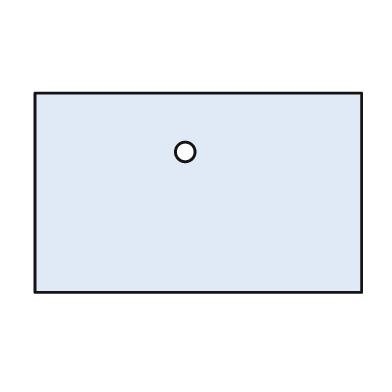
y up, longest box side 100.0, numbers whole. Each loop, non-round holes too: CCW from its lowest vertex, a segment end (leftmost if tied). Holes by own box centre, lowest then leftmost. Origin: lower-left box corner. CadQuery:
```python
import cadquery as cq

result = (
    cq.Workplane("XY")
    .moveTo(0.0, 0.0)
    .lineTo(100.0, 0.0)
    .lineTo(100.0, 61.0)
    .lineTo(0.0, 61.0)
    .close()
    .moveTo(46.0, 43.0)
    .circle(3.0)
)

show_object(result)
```